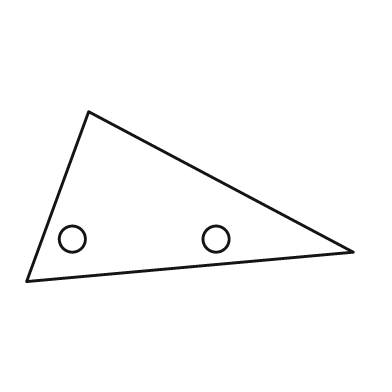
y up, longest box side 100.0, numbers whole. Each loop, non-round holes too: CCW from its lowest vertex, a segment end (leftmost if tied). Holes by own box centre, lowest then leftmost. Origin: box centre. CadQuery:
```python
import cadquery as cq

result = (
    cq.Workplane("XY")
    .moveTo(-50.0, -26.0)
    .lineTo(50.0, -17.0)
    .lineTo(-31.0, 26.0)
    .close()
    .moveTo(-36.0, -13.0)
    .circle(4.0)
    .moveTo(8.0, -13.0)
    .circle(4.0)
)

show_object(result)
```